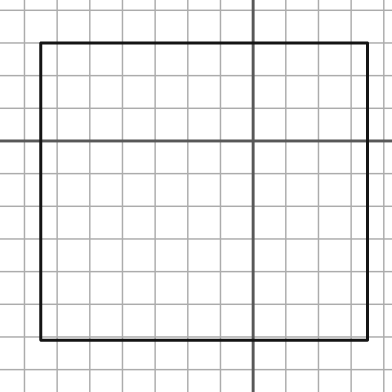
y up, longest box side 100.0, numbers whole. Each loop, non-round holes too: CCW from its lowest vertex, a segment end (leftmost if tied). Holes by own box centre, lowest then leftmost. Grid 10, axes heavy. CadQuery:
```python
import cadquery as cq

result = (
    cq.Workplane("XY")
    .moveTo(-65.0, -61.0)
    .lineTo(35.0, -61.0)
    .lineTo(35.0, 30.0)
    .lineTo(-65.0, 30.0)
    .close()
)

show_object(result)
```